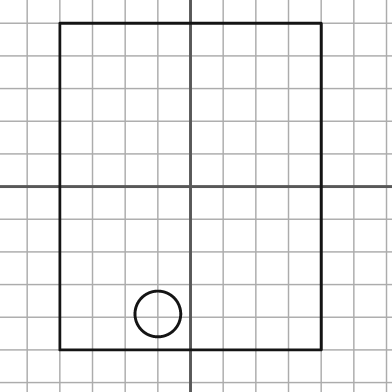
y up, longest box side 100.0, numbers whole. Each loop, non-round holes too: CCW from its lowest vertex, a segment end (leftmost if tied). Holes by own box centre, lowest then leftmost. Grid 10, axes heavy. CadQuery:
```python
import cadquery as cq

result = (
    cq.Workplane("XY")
    .moveTo(-40.0, -50.0)
    .lineTo(40.0, -50.0)
    .lineTo(40.0, 50.0)
    .lineTo(-40.0, 50.0)
    .close()
    .moveTo(-10.0, -39.0)
    .circle(7.0)
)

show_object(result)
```